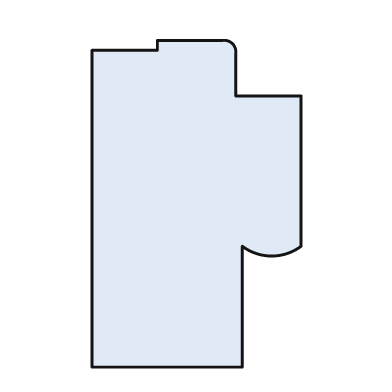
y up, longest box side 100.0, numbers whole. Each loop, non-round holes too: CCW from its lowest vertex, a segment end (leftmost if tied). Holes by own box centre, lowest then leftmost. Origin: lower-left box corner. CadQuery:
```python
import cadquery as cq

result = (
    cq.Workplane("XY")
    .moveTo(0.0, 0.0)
    .lineTo(46.0, 0.0)
    .lineTo(46.0, 37.0)
    .threePointArc((55.0, 34.0), (64.0, 37.0))
    .lineTo(64.0, 83.0)
    .lineTo(44.0, 83.0)
    .lineTo(44.0, 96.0)
    .threePointArc((43.0, 99.0), (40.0, 100.0))
    .lineTo(20.0, 100.0)
    .lineTo(20.0, 97.0)
    .lineTo(0.0, 97.0)
    .close()
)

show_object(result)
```